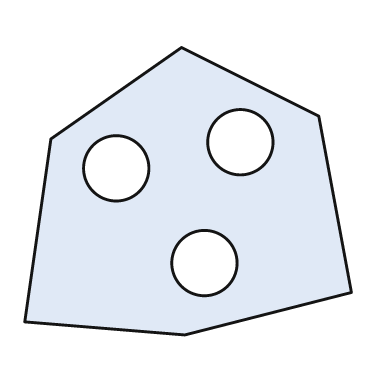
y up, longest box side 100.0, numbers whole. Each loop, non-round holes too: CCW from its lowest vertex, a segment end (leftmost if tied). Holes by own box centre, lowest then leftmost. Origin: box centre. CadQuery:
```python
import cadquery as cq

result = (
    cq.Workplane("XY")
    .moveTo(-1.0, -44.0)
    .lineTo(50.0, -31.0)
    .lineTo(40.0, 23.0)
    .lineTo(-2.0, 44.0)
    .lineTo(-42.0, 16.0)
    .lineTo(-50.0, -40.0)
    .close()
    .moveTo(5.0, -22.0)
    .circle(10.0)
    .moveTo(-22.0, 7.0)
    .circle(10.0)
    .moveTo(16.0, 15.0)
    .circle(10.0)
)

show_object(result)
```